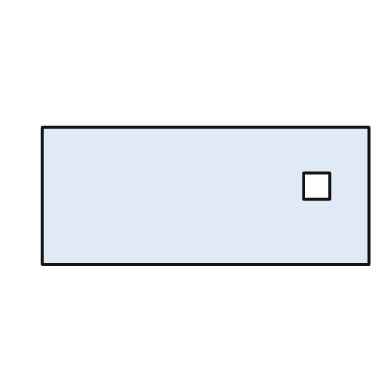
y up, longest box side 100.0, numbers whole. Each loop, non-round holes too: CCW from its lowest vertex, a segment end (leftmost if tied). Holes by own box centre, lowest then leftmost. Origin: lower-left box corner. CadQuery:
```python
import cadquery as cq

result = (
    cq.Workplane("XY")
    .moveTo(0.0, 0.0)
    .lineTo(100.0, 0.0)
    .lineTo(100.0, 42.0)
    .lineTo(0.0, 42.0)
    .close()
    .moveTo(80.0, 20.0)
    .lineTo(88.0, 20.0)
    .lineTo(88.0, 28.0)
    .lineTo(80.0, 28.0)
    .close()
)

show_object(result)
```